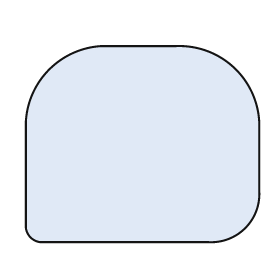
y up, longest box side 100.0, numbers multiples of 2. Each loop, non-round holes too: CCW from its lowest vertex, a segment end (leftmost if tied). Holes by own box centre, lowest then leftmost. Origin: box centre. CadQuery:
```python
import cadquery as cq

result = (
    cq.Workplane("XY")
    .moveTo(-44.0, -42.0)
    .lineTo(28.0, -42.0)
    .threePointArc((44.0, -36.0), (50.0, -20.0))
    .lineTo(50.0, 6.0)
    .threePointArc((40.0, 32.0), (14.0, 42.0))
    .lineTo(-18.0, 42.0)
    .threePointArc((-40.0, 32.0), (-50.0, 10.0))
    .lineTo(-50.0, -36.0)
    .threePointArc((-48.0, -40.0), (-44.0, -42.0))
    .close()
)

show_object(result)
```